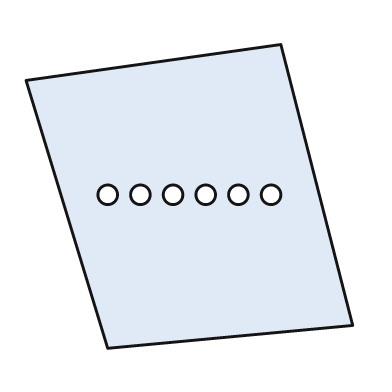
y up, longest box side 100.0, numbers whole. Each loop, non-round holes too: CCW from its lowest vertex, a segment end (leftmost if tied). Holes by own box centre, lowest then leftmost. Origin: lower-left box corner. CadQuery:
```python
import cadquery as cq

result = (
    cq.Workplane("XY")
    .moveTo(25.0, 0.0)
    .lineTo(100.0, 7.0)
    .lineTo(78.0, 93.0)
    .lineTo(0.0, 82.0)
    .close()
    .moveTo(25.0, 47.0)
    .circle(3.0)
    .moveTo(35.0, 47.0)
    .circle(3.0)
    .moveTo(45.0, 47.0)
    .circle(3.0)
    .moveTo(55.0, 47.0)
    .circle(3.0)
    .moveTo(65.0, 47.0)
    .circle(3.0)
    .moveTo(75.0, 47.0)
    .circle(3.0)
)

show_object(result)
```